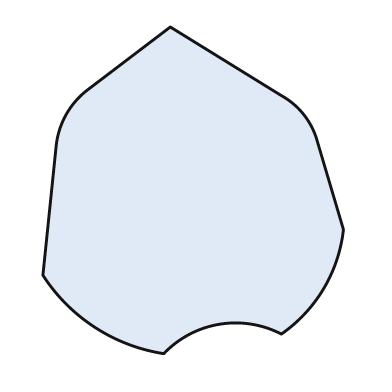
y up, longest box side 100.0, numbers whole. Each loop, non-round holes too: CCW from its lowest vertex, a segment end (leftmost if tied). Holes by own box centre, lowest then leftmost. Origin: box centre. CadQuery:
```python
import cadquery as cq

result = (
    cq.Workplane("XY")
    .moveTo(-9.0, -50.0)
    .threePointArc((8.0, -41.0), (27.0, -44.0))
    .threePointArc((40.0, -30.0), (46.0, -12.0))
    .lineTo(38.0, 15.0)
    .threePointArc((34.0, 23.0), (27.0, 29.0))
    .lineTo(-7.0, 50.0)
    .lineTo(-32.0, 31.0)
    .threePointArc((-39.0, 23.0), (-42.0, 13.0))
    .lineTo(-46.0, -26.0)
    .threePointArc((-30.0, -42.0), (-9.0, -50.0))
    .close()
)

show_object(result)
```